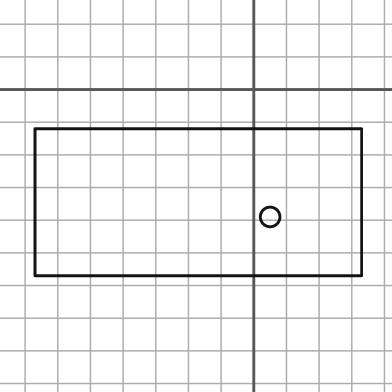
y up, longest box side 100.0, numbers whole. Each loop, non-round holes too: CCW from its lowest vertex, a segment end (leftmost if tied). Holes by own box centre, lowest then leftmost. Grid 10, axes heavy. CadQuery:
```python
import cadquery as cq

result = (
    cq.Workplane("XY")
    .moveTo(-67.0, -57.0)
    .lineTo(33.0, -57.0)
    .lineTo(33.0, -12.0)
    .lineTo(-67.0, -12.0)
    .close()
    .moveTo(5.0, -39.0)
    .circle(3.0)
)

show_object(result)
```